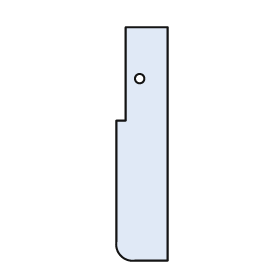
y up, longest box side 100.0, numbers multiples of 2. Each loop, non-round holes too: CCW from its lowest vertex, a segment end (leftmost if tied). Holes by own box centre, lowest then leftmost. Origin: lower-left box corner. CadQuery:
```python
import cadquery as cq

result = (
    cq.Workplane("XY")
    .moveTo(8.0, 0.0)
    .lineTo(22.0, 0.0)
    .lineTo(22.0, 100.0)
    .lineTo(4.0, 100.0)
    .lineTo(4.0, 60.0)
    .lineTo(0.0, 60.0)
    .lineTo(0.0, 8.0)
    .threePointArc((2.0, 2.0), (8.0, 0.0))
    .close()
    .moveTo(10.0, 78.0)
    .circle(2.0)
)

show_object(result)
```